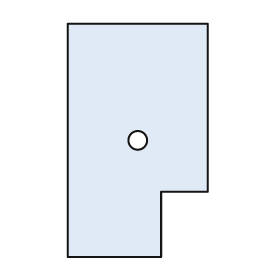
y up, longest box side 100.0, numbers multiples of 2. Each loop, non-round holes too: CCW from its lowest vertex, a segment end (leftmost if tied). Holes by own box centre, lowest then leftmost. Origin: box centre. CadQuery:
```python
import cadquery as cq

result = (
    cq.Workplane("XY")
    .moveTo(-30.0, -50.0)
    .lineTo(10.0, -50.0)
    .lineTo(10.0, -22.0)
    .lineTo(30.0, -22.0)
    .lineTo(30.0, 50.0)
    .lineTo(-30.0, 50.0)
    .close()
    .moveTo(0.0, 0.0)
    .circle(4.0)
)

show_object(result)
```